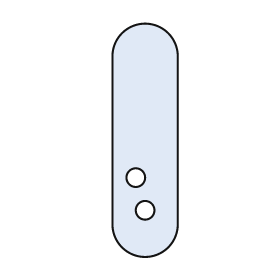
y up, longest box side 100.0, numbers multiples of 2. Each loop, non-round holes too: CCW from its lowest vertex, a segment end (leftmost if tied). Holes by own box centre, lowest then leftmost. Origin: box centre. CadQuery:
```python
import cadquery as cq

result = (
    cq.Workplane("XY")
    .moveTo(-14.0, -36.0)
    .threePointArc((0.0, -50.0), (14.0, -36.0))
    .lineTo(14.0, 36.0)
    .threePointArc((0.0, 50.0), (-14.0, 36.0))
    .close()
    .moveTo(0.0, -30.0)
    .circle(4.0)
    .moveTo(-4.0, -16.0)
    .circle(4.0)
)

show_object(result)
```